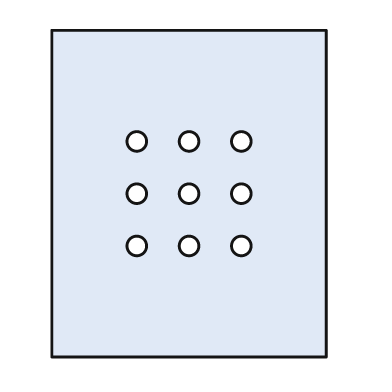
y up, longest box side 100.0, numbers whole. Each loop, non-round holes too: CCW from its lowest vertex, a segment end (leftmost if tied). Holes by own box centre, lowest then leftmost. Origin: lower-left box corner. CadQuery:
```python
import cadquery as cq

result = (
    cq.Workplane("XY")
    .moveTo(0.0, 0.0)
    .lineTo(84.0, 0.0)
    .lineTo(84.0, 100.0)
    .lineTo(0.0, 100.0)
    .close()
    .moveTo(26.0, 34.0)
    .circle(3.0)
    .moveTo(42.0, 34.0)
    .circle(3.0)
    .moveTo(58.0, 34.0)
    .circle(3.0)
    .moveTo(26.0, 50.0)
    .circle(3.0)
    .moveTo(42.0, 50.0)
    .circle(3.0)
    .moveTo(58.0, 50.0)
    .circle(3.0)
    .moveTo(26.0, 66.0)
    .circle(3.0)
    .moveTo(42.0, 66.0)
    .circle(3.0)
    .moveTo(58.0, 66.0)
    .circle(3.0)
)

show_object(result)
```